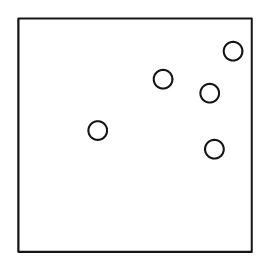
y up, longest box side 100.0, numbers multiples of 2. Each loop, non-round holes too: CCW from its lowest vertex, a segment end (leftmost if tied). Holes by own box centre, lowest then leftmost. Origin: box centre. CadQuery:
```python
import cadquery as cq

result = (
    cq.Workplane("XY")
    .moveTo(-50.0, -50.0)
    .lineTo(50.0, -50.0)
    .lineTo(50.0, 50.0)
    .lineTo(-50.0, 50.0)
    .close()
    .moveTo(34.0, -6.0)
    .circle(4.0)
    .moveTo(-16.0, 2.0)
    .circle(4.0)
    .moveTo(32.0, 18.0)
    .circle(4.0)
    .moveTo(12.0, 24.0)
    .circle(4.0)
    .moveTo(42.0, 36.0)
    .circle(4.0)
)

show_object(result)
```